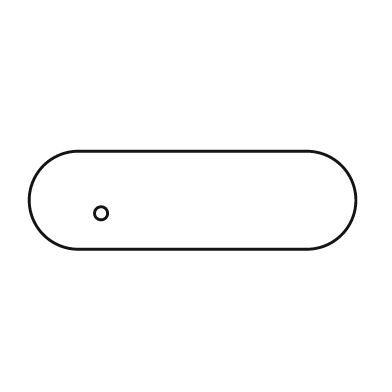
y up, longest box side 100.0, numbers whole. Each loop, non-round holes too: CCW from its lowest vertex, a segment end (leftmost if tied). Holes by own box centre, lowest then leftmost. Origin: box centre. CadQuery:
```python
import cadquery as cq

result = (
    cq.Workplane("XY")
    .moveTo(-35.0, -15.0)
    .lineTo(35.0, -15.0)
    .threePointArc((50.0, 0.0), (35.0, 15.0))
    .lineTo(-35.0, 15.0)
    .threePointArc((-50.0, 0.0), (-35.0, -15.0))
    .close()
    .moveTo(-28.0, -4.0)
    .circle(2.0)
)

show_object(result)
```